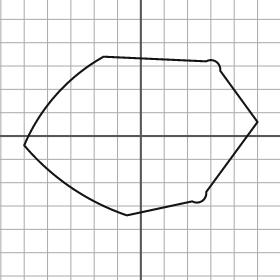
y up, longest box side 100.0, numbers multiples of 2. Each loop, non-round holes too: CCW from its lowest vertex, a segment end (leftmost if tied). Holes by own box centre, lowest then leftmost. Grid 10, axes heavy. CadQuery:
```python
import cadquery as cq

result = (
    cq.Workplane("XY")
    .moveTo(-6.0, -34.0)
    .lineTo(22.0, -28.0)
    .threePointArc((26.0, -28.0), (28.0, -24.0))
    .lineTo(50.0, 6.0)
    .lineTo(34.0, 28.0)
    .threePointArc((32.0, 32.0), (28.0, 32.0))
    .lineTo(-16.0, 34.0)
    .threePointArc((-36.0, 18.0), (-50.0, -4.0))
    .threePointArc((-30.0, -22.0), (-6.0, -34.0))
    .close()
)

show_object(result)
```